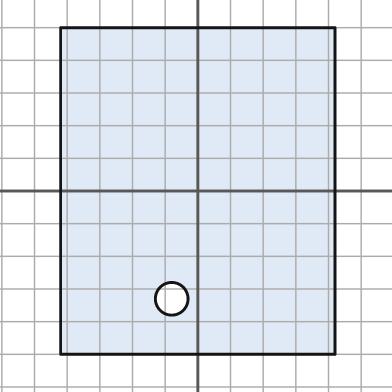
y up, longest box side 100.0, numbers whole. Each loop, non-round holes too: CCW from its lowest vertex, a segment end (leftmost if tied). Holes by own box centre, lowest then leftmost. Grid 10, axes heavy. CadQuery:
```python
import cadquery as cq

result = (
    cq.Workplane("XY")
    .moveTo(-42.0, -50.0)
    .lineTo(42.0, -50.0)
    .lineTo(42.0, 50.0)
    .lineTo(-42.0, 50.0)
    .close()
    .moveTo(-8.0, -33.0)
    .circle(5.0)
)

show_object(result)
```